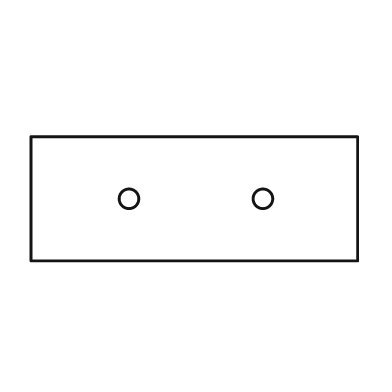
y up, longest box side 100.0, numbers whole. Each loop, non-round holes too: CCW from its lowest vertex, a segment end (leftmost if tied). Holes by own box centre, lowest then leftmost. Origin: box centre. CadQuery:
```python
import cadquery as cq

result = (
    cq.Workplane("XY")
    .moveTo(-50.0, -19.0)
    .lineTo(50.0, -19.0)
    .lineTo(50.0, 19.0)
    .lineTo(-50.0, 19.0)
    .close()
    .moveTo(-20.0, 0.0)
    .circle(3.0)
    .moveTo(21.0, 0.0)
    .circle(3.0)
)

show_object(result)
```